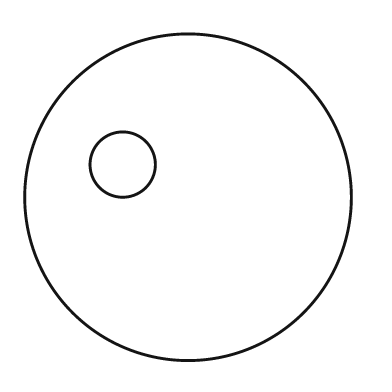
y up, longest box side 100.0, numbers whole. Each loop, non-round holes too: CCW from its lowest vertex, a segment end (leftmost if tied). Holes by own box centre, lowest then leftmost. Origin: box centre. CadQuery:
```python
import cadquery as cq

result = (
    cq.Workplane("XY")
    .moveTo(0.0, 0.0)
    .circle(50.0)
    .moveTo(-20.0, 10.0)
    .circle(10.0)
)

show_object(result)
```